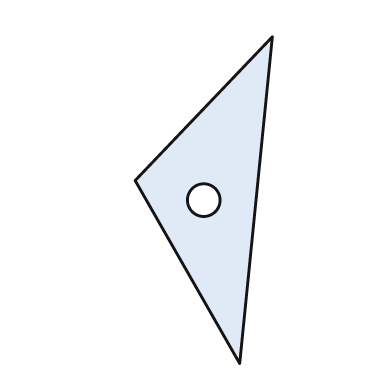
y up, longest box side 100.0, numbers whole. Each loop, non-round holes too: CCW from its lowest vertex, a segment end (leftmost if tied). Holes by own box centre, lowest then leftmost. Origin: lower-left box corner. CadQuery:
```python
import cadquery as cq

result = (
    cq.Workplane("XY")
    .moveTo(32.0, 0.0)
    .lineTo(42.0, 100.0)
    .lineTo(0.0, 56.0)
    .close()
    .moveTo(21.0, 50.0)
    .circle(5.0)
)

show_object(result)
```